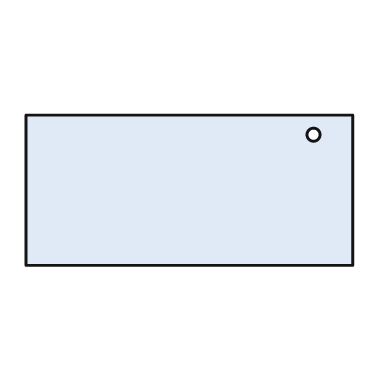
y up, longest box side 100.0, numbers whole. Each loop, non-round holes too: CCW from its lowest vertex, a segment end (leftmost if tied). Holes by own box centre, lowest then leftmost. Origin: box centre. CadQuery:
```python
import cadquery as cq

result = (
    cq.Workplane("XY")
    .moveTo(-50.0, -23.0)
    .lineTo(50.0, -23.0)
    .lineTo(50.0, 23.0)
    .lineTo(-50.0, 23.0)
    .close()
    .moveTo(38.0, 17.0)
    .circle(2.0)
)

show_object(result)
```